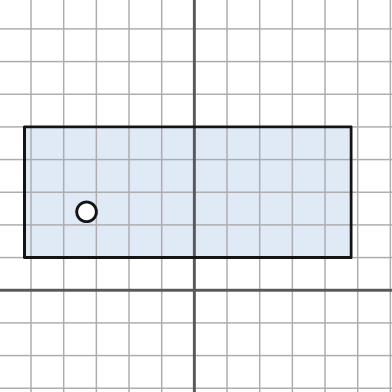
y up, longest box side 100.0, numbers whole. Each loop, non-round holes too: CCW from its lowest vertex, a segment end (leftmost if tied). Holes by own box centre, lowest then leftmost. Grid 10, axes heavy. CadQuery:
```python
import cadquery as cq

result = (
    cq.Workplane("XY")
    .moveTo(-52.0, 10.0)
    .lineTo(48.0, 10.0)
    .lineTo(48.0, 50.0)
    .lineTo(-52.0, 50.0)
    .close()
    .moveTo(-33.0, 24.0)
    .circle(3.0)
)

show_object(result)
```